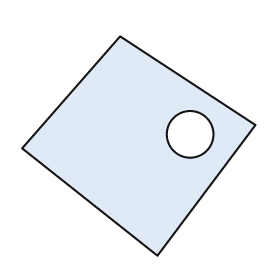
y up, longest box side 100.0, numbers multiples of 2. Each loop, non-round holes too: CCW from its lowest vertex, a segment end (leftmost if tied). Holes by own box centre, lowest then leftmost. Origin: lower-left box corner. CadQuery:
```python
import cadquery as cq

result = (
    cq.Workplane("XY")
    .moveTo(58.0, 0.0)
    .lineTo(100.0, 56.0)
    .lineTo(42.0, 94.0)
    .lineTo(0.0, 46.0)
    .close()
    .moveTo(72.0, 52.0)
    .circle(10.0)
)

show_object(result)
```